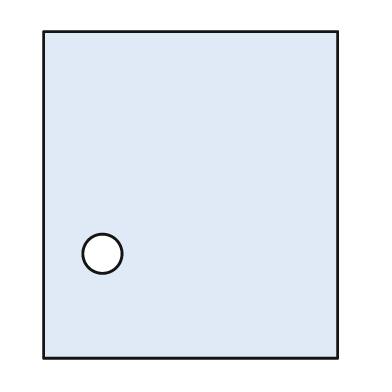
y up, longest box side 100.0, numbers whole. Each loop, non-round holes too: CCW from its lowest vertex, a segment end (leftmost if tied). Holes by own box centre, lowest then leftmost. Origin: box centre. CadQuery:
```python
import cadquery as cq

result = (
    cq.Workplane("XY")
    .moveTo(-45.0, -50.0)
    .lineTo(45.0, -50.0)
    .lineTo(45.0, 50.0)
    .lineTo(-45.0, 50.0)
    .close()
    .moveTo(-27.0, -18.0)
    .circle(6.0)
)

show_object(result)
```